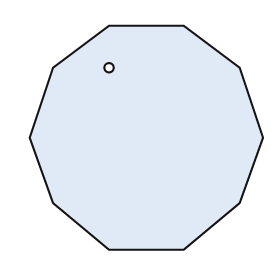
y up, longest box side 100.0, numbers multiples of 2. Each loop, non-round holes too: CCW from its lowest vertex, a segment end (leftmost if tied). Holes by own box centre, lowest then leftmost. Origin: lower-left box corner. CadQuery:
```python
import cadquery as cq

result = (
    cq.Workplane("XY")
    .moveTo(34.0, 0.0)
    .lineTo(66.0, 0.0)
    .lineTo(90.0, 20.0)
    .lineTo(100.0, 48.0)
    .lineTo(90.0, 78.0)
    .lineTo(66.0, 96.0)
    .lineTo(34.0, 96.0)
    .lineTo(10.0, 78.0)
    .lineTo(0.0, 48.0)
    .lineTo(10.0, 20.0)
    .close()
    .moveTo(34.0, 78.0)
    .circle(2.0)
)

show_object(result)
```